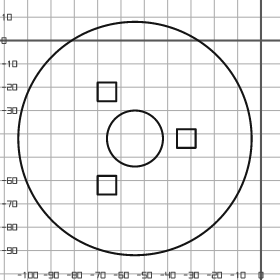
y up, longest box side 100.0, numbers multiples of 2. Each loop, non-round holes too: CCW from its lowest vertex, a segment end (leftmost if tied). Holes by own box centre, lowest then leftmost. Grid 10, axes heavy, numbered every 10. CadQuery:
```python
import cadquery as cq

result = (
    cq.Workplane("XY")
    .moveTo(-54.0, -42.0)
    .circle(50.0)
    .moveTo(-70.0, -66.0)
    .lineTo(-62.0, -66.0)
    .lineTo(-62.0, -58.0)
    .lineTo(-70.0, -58.0)
    .close()
    .moveTo(-54.0, -42.0)
    .circle(12.0)
    .moveTo(-36.0, -46.0)
    .lineTo(-28.0, -46.0)
    .lineTo(-28.0, -38.0)
    .lineTo(-36.0, -38.0)
    .close()
    .moveTo(-70.0, -26.0)
    .lineTo(-62.0, -26.0)
    .lineTo(-62.0, -18.0)
    .lineTo(-70.0, -18.0)
    .close()
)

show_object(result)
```